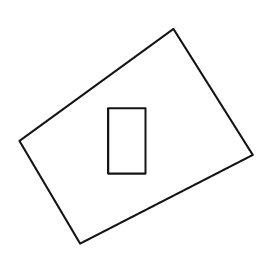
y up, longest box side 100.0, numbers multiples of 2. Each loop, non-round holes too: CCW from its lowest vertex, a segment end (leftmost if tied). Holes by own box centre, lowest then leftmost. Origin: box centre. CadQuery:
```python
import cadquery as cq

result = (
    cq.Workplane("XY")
    .moveTo(-24.0, -46.0)
    .lineTo(50.0, -8.0)
    .lineTo(16.0, 46.0)
    .lineTo(-50.0, -2.0)
    .close()
    .moveTo(-12.0, -16.0)
    .lineTo(4.0, -16.0)
    .lineTo(4.0, 12.0)
    .lineTo(-12.0, 12.0)
    .close()
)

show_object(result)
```